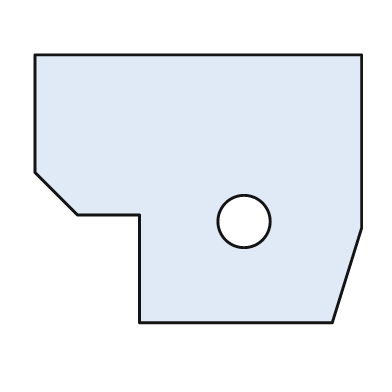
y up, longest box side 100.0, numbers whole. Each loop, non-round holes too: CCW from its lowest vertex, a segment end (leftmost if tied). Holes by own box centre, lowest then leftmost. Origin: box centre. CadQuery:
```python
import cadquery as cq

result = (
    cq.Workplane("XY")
    .moveTo(-18.0, -41.0)
    .lineTo(41.0, -41.0)
    .lineTo(50.0, -12.0)
    .lineTo(50.0, 41.0)
    .lineTo(-50.0, 41.0)
    .lineTo(-50.0, 5.0)
    .lineTo(-37.0, -8.0)
    .lineTo(-18.0, -8.0)
    .close()
    .moveTo(14.0, -10.0)
    .circle(8.0)
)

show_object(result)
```